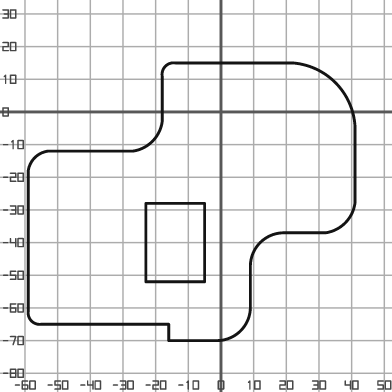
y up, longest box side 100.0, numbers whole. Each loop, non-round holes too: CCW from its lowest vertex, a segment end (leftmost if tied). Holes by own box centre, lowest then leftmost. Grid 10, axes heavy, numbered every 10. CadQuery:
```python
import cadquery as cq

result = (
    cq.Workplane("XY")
    .moveTo(-16.0, -70.0)
    .lineTo(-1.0, -70.0)
    .threePointArc((6.0, -67.0), (9.0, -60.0))
    .lineTo(9.0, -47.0)
    .threePointArc((12.0, -40.0), (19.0, -37.0))
    .lineTo(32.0, -37.0)
    .threePointArc((38.0, -34.0), (41.0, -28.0))
    .lineTo(41.0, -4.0)
    .threePointArc((35.0, 9.0), (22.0, 15.0))
    .lineTo(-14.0, 15.0)
    .threePointArc((-17.0, 14.0), (-18.0, 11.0))
    .lineTo(-18.0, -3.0)
    .threePointArc((-21.0, -9.0), (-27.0, -12.0))
    .lineTo(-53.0, -12.0)
    .threePointArc((-57.0, -14.0), (-59.0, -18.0))
    .lineTo(-59.0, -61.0)
    .threePointArc((-58.0, -64.0), (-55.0, -65.0))
    .lineTo(-16.0, -65.0)
    .close()
    .moveTo(-23.0, -52.0)
    .lineTo(-5.0, -52.0)
    .lineTo(-5.0, -28.0)
    .lineTo(-23.0, -28.0)
    .close()
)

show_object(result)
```